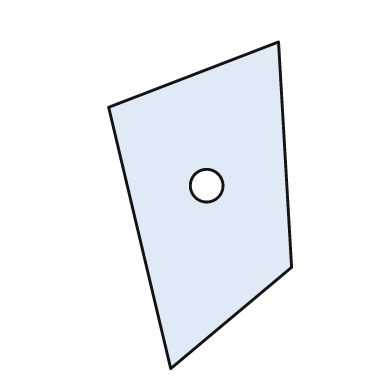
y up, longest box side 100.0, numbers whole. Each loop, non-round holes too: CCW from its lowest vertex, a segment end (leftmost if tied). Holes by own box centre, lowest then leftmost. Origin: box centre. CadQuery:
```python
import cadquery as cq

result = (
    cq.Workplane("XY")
    .moveTo(-9.0, -50.0)
    .lineTo(28.0, -19.0)
    .lineTo(24.0, 50.0)
    .lineTo(-28.0, 30.0)
    .close()
    .moveTo(2.0, 6.0)
    .circle(5.0)
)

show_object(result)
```